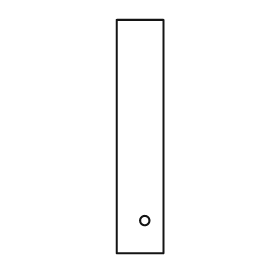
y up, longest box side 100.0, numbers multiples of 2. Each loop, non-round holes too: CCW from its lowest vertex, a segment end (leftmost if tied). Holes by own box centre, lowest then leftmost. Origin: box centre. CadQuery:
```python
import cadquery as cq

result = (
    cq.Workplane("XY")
    .moveTo(-10.0, -50.0)
    .lineTo(10.0, -50.0)
    .lineTo(10.0, 50.0)
    .lineTo(-10.0, 50.0)
    .close()
    .moveTo(2.0, -36.0)
    .circle(2.0)
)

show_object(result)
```